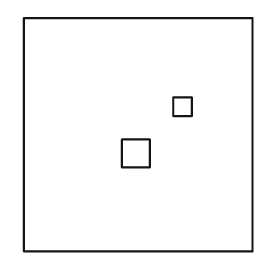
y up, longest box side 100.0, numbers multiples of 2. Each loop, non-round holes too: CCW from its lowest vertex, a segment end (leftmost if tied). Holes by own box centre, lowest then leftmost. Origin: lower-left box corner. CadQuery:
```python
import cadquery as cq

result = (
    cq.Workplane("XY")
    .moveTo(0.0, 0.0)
    .lineTo(98.0, 0.0)
    .lineTo(98.0, 100.0)
    .lineTo(0.0, 100.0)
    .close()
    .moveTo(42.0, 36.0)
    .lineTo(54.0, 36.0)
    .lineTo(54.0, 48.0)
    .lineTo(42.0, 48.0)
    .close()
    .moveTo(64.0, 58.0)
    .lineTo(72.0, 58.0)
    .lineTo(72.0, 66.0)
    .lineTo(64.0, 66.0)
    .close()
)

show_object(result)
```